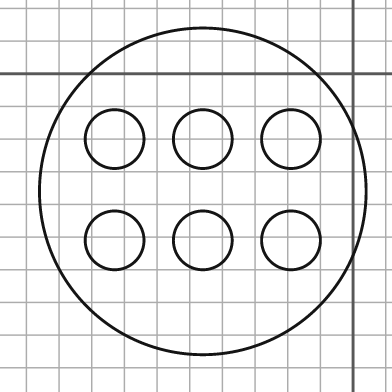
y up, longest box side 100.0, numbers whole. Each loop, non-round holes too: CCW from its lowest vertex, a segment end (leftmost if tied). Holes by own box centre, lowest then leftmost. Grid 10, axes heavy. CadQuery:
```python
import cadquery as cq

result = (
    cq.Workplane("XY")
    .moveTo(-46.0, -36.0)
    .circle(50.0)
    .moveTo(-73.0, -51.0)
    .circle(9.0)
    .moveTo(-46.0, -51.0)
    .circle(9.0)
    .moveTo(-19.0, -51.0)
    .circle(9.0)
    .moveTo(-73.0, -20.0)
    .circle(9.0)
    .moveTo(-46.0, -20.0)
    .circle(9.0)
    .moveTo(-19.0, -20.0)
    .circle(9.0)
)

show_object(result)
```